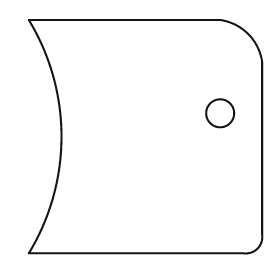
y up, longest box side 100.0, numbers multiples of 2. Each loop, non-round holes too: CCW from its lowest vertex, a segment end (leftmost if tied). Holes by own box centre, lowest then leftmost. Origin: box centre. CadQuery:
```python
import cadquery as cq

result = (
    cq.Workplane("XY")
    .moveTo(-50.0, -50.0)
    .lineTo(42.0, -50.0)
    .threePointArc((48.0, -48.0), (50.0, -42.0))
    .lineTo(50.0, 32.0)
    .threePointArc((44.0, 44.0), (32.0, 50.0))
    .lineTo(-50.0, 50.0)
    .threePointArc((-36.0, 0.0), (-50.0, -50.0))
    .close()
    .moveTo(32.0, 10.0)
    .circle(6.0)
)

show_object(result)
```